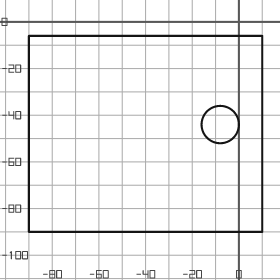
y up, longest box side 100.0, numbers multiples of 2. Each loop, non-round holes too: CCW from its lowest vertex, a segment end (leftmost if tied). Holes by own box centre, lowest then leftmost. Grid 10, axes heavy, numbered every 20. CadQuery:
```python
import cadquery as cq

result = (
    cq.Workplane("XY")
    .moveTo(-90.0, -90.0)
    .lineTo(10.0, -90.0)
    .lineTo(10.0, -6.0)
    .lineTo(-90.0, -6.0)
    .close()
    .moveTo(-8.0, -44.0)
    .circle(8.0)
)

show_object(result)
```